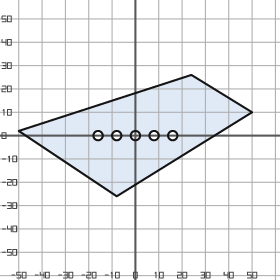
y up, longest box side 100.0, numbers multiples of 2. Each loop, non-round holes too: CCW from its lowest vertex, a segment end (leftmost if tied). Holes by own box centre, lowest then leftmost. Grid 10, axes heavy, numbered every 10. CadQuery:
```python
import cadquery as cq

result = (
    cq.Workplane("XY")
    .moveTo(-8.0, -26.0)
    .lineTo(50.0, 10.0)
    .lineTo(24.0, 26.0)
    .lineTo(-50.0, 2.0)
    .close()
    .moveTo(-16.0, 0.0)
    .circle(2.0)
    .moveTo(-8.0, 0.0)
    .circle(2.0)
    .moveTo(0.0, 0.0)
    .circle(2.0)
    .moveTo(8.0, 0.0)
    .circle(2.0)
    .moveTo(16.0, 0.0)
    .circle(2.0)
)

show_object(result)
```